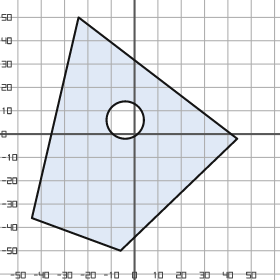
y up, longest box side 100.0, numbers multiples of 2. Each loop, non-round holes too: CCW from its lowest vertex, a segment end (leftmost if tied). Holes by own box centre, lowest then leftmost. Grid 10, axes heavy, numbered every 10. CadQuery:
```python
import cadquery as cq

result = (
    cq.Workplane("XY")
    .moveTo(-6.0, -50.0)
    .lineTo(44.0, -2.0)
    .lineTo(-24.0, 50.0)
    .lineTo(-44.0, -36.0)
    .close()
    .moveTo(-4.0, 6.0)
    .circle(8.0)
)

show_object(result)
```